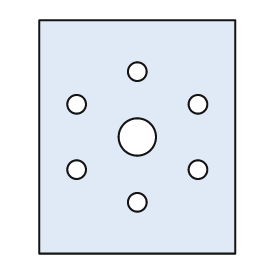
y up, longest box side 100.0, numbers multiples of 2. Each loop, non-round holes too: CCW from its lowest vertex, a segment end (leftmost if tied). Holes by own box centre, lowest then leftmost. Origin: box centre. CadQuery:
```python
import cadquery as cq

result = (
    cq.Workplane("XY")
    .moveTo(-42.0, -50.0)
    .lineTo(42.0, -50.0)
    .lineTo(42.0, 50.0)
    .lineTo(-42.0, 50.0)
    .close()
    .moveTo(0.0, -28.0)
    .circle(4.0)
    .moveTo(-26.0, -14.0)
    .circle(4.0)
    .moveTo(26.0, -14.0)
    .circle(4.0)
    .moveTo(0.0, 0.0)
    .circle(8.0)
    .moveTo(-26.0, 14.0)
    .circle(4.0)
    .moveTo(26.0, 14.0)
    .circle(4.0)
    .moveTo(0.0, 28.0)
    .circle(4.0)
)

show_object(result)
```